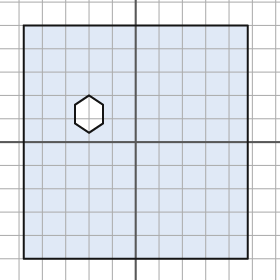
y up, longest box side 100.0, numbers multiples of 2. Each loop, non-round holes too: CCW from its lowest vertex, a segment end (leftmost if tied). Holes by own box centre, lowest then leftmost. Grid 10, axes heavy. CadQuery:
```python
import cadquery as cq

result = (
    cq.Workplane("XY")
    .moveTo(-48.0, -50.0)
    .lineTo(48.0, -50.0)
    .lineTo(48.0, 50.0)
    .lineTo(-48.0, 50.0)
    .close()
    .moveTo(-20.0, 4.0)
    .lineTo(-14.0, 8.0)
    .lineTo(-14.0, 16.0)
    .lineTo(-20.0, 20.0)
    .lineTo(-26.0, 16.0)
    .lineTo(-26.0, 8.0)
    .close()
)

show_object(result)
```